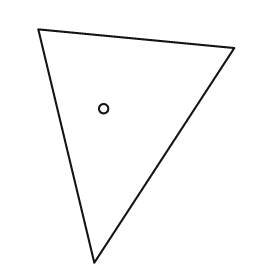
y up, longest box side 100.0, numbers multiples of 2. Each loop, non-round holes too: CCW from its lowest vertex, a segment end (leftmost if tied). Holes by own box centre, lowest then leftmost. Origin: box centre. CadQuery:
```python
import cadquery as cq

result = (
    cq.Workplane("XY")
    .moveTo(-18.0, -50.0)
    .lineTo(42.0, 42.0)
    .lineTo(-42.0, 50.0)
    .close()
    .moveTo(-14.0, 16.0)
    .circle(2.0)
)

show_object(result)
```